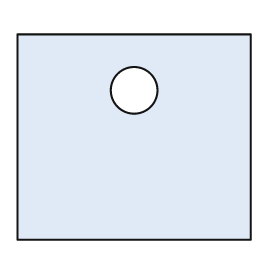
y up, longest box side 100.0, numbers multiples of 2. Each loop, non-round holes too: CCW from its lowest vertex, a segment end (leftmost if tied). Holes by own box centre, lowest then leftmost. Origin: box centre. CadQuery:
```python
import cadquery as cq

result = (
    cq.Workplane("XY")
    .moveTo(-50.0, -44.0)
    .lineTo(50.0, -44.0)
    .lineTo(50.0, 44.0)
    .lineTo(-50.0, 44.0)
    .close()
    .moveTo(0.0, 20.0)
    .circle(10.0)
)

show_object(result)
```